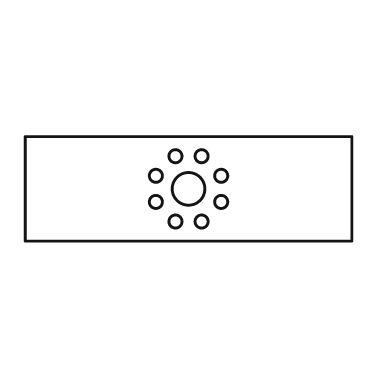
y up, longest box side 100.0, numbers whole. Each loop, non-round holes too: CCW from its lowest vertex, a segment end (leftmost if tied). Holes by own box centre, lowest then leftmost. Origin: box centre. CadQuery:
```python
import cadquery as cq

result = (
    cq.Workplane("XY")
    .moveTo(-50.0, -16.0)
    .lineTo(50.0, -16.0)
    .lineTo(50.0, 16.0)
    .lineTo(-50.0, 16.0)
    .close()
    .moveTo(-4.0, -10.0)
    .circle(2.0)
    .moveTo(4.0, -10.0)
    .circle(2.0)
    .moveTo(-10.0, -4.0)
    .circle(2.0)
    .moveTo(10.0, -4.0)
    .circle(2.0)
    .moveTo(0.0, 0.0)
    .circle(5.0)
    .moveTo(-10.0, 4.0)
    .circle(2.0)
    .moveTo(10.0, 4.0)
    .circle(2.0)
    .moveTo(-4.0, 10.0)
    .circle(2.0)
    .moveTo(4.0, 10.0)
    .circle(2.0)
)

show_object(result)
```